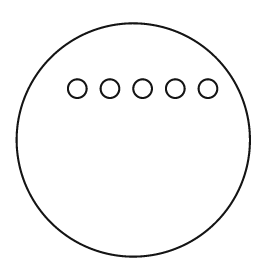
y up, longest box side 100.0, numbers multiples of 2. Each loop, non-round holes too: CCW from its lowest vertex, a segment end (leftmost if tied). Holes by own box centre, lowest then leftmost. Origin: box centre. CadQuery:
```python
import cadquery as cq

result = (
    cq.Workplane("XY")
    .moveTo(0.0, 0.0)
    .circle(50.0)
    .moveTo(-24.0, 22.0)
    .circle(4.0)
    .moveTo(-10.0, 22.0)
    .circle(4.0)
    .moveTo(4.0, 22.0)
    .circle(4.0)
    .moveTo(18.0, 22.0)
    .circle(4.0)
    .moveTo(32.0, 22.0)
    .circle(4.0)
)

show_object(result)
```